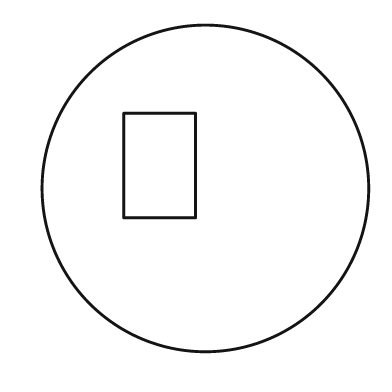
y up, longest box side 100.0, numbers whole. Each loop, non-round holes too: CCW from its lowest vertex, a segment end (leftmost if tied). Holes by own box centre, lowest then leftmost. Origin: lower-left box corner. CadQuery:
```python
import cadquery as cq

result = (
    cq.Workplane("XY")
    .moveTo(50.0, 50.0)
    .circle(50.0)
    .moveTo(25.0, 41.0)
    .lineTo(47.0, 41.0)
    .lineTo(47.0, 73.0)
    .lineTo(25.0, 73.0)
    .close()
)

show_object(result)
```